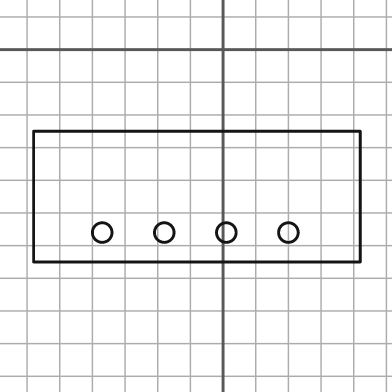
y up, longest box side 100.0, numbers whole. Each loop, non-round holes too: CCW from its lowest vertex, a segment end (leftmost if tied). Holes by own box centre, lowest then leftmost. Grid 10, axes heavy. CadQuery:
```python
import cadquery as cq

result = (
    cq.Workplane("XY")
    .moveTo(-58.0, -65.0)
    .lineTo(42.0, -65.0)
    .lineTo(42.0, -25.0)
    .lineTo(-58.0, -25.0)
    .close()
    .moveTo(-37.0, -56.0)
    .circle(3.0)
    .moveTo(-18.0, -56.0)
    .circle(3.0)
    .moveTo(1.0, -56.0)
    .circle(3.0)
    .moveTo(20.0, -56.0)
    .circle(3.0)
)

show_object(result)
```